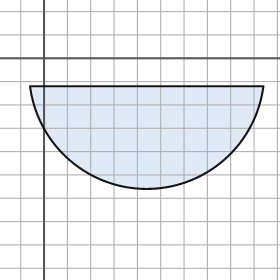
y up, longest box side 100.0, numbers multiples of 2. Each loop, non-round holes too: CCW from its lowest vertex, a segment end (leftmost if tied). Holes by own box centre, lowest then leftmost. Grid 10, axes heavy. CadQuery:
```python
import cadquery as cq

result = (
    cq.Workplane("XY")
    .moveTo(-6.0, -12.0)
    .threePointArc((44.0, -56.0), (94.0, -12.0))
    .close()
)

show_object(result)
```